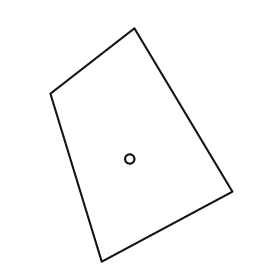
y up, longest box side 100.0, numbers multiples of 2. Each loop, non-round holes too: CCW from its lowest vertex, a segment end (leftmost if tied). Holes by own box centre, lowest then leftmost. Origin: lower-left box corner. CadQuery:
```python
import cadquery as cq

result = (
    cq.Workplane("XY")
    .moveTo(22.0, 0.0)
    .lineTo(78.0, 30.0)
    .lineTo(36.0, 100.0)
    .lineTo(0.0, 72.0)
    .close()
    .moveTo(34.0, 44.0)
    .circle(2.0)
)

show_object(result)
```